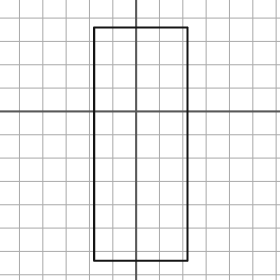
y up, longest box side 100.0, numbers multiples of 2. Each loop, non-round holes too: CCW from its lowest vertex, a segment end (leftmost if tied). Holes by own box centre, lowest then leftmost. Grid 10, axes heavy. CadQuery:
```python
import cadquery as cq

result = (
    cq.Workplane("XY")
    .moveTo(-18.0, -64.0)
    .lineTo(22.0, -64.0)
    .lineTo(22.0, 36.0)
    .lineTo(-18.0, 36.0)
    .close()
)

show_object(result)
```